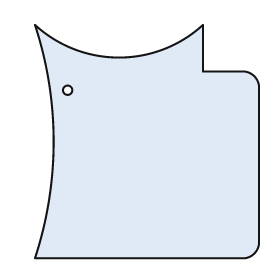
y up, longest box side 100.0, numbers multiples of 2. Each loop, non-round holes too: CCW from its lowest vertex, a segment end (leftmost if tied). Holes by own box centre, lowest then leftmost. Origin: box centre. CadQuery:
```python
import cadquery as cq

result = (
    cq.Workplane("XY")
    .moveTo(-48.0, -50.0)
    .lineTo(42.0, -50.0)
    .threePointArc((46.0, -48.0), (48.0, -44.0))
    .lineTo(48.0, 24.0)
    .threePointArc((46.0, 28.0), (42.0, 30.0))
    .lineTo(24.0, 30.0)
    .lineTo(24.0, 50.0)
    .threePointArc((-12.0, 36.0), (-48.0, 50.0))
    .threePointArc((-40.0, 0.0), (-48.0, -50.0))
    .close()
    .moveTo(-34.0, 22.0)
    .circle(2.0)
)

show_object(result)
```